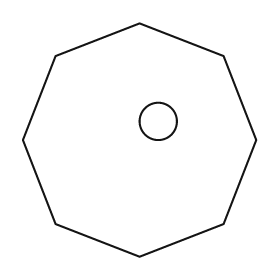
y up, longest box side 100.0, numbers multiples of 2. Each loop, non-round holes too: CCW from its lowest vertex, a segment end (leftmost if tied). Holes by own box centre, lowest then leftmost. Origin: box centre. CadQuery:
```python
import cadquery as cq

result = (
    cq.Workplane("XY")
    .moveTo(0.0, -50.0)
    .lineTo(36.0, -36.0)
    .lineTo(50.0, 0.0)
    .lineTo(36.0, 36.0)
    .lineTo(0.0, 50.0)
    .lineTo(-36.0, 36.0)
    .lineTo(-50.0, 0.0)
    .lineTo(-36.0, -36.0)
    .close()
    .moveTo(8.0, 8.0)
    .circle(8.0)
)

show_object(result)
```